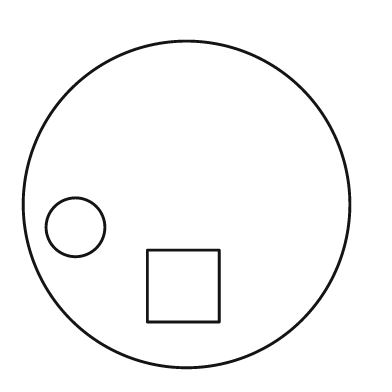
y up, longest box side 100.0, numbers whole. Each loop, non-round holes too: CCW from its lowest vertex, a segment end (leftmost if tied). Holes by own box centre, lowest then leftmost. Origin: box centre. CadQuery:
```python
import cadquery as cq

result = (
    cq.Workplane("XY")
    .moveTo(0.0, 0.0)
    .circle(50.0)
    .moveTo(-12.0, -36.0)
    .lineTo(10.0, -36.0)
    .lineTo(10.0, -14.0)
    .lineTo(-12.0, -14.0)
    .close()
    .moveTo(-34.0, -7.0)
    .circle(9.0)
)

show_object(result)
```